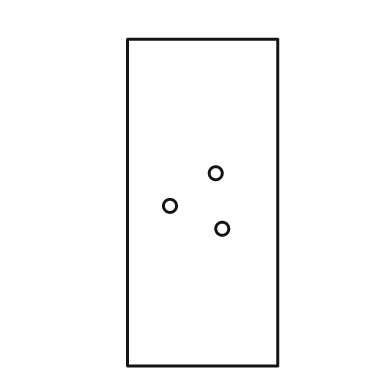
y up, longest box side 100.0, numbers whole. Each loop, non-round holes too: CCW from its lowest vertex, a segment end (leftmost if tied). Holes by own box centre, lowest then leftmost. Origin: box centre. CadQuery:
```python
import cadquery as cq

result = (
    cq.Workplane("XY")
    .moveTo(-23.0, -50.0)
    .lineTo(23.0, -50.0)
    .lineTo(23.0, 50.0)
    .lineTo(-23.0, 50.0)
    .close()
    .moveTo(6.0, -8.0)
    .circle(2.0)
    .moveTo(-10.0, -1.0)
    .circle(2.0)
    .moveTo(4.0, 9.0)
    .circle(2.0)
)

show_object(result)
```